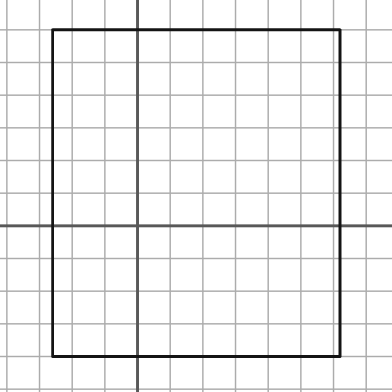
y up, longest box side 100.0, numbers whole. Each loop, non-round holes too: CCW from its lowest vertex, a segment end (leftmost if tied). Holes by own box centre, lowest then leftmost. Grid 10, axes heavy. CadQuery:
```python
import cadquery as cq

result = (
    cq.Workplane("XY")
    .moveTo(-26.0, -40.0)
    .lineTo(62.0, -40.0)
    .lineTo(62.0, 60.0)
    .lineTo(-26.0, 60.0)
    .close()
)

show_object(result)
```